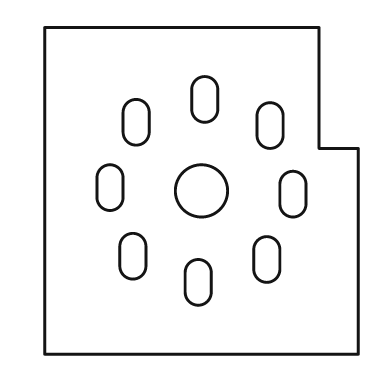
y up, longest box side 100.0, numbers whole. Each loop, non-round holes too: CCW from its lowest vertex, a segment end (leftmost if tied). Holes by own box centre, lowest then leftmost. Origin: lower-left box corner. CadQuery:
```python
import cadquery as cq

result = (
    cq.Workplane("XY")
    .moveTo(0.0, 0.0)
    .lineTo(96.0, 0.0)
    .lineTo(96.0, 63.0)
    .lineTo(84.0, 63.0)
    .lineTo(84.0, 100.0)
    .lineTo(0.0, 100.0)
    .close()
    .moveTo(43.0, 19.0)
    .threePointArc((47.0, 15.0), (51.0, 19.0))
    .lineTo(51.0, 25.0)
    .threePointArc((47.0, 29.0), (43.0, 25.0))
    .close()
    .moveTo(64.0, 26.0)
    .threePointArc((68.0, 22.0), (72.0, 26.0))
    .lineTo(72.0, 32.0)
    .threePointArc((68.0, 36.0), (64.0, 32.0))
    .close()
    .moveTo(23.0, 27.0)
    .threePointArc((27.0, 23.0), (31.0, 27.0))
    .lineTo(31.0, 33.0)
    .threePointArc((27.0, 37.0), (23.0, 33.0))
    .close()
    .moveTo(72.0, 46.0)
    .threePointArc((76.0, 42.0), (80.0, 46.0))
    .lineTo(80.0, 52.0)
    .threePointArc((76.0, 56.0), (72.0, 52.0))
    .close()
    .moveTo(48.0, 50.0)
    .circle(8.0)
    .moveTo(16.0, 48.0)
    .threePointArc((20.0, 44.0), (24.0, 48.0))
    .lineTo(24.0, 54.0)
    .threePointArc((20.0, 58.0), (16.0, 54.0))
    .close()
    .moveTo(65.0, 67.0)
    .threePointArc((69.0, 63.0), (73.0, 67.0))
    .lineTo(73.0, 73.0)
    .threePointArc((69.0, 77.0), (65.0, 73.0))
    .close()
    .moveTo(24.0, 68.0)
    .threePointArc((28.0, 64.0), (32.0, 68.0))
    .lineTo(32.0, 74.0)
    .threePointArc((28.0, 78.0), (24.0, 74.0))
    .close()
    .moveTo(45.0, 75.0)
    .threePointArc((49.0, 71.0), (53.0, 75.0))
    .lineTo(53.0, 81.0)
    .threePointArc((49.0, 85.0), (45.0, 81.0))
    .close()
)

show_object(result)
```